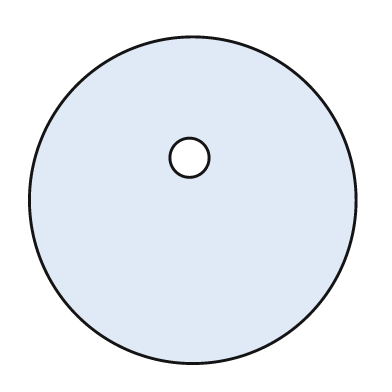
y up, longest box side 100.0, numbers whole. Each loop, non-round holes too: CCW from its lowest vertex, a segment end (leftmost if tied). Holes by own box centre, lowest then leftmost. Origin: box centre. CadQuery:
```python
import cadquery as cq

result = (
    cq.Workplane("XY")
    .moveTo(0.0, 0.0)
    .circle(50.0)
    .moveTo(-1.0, 13.0)
    .circle(6.0)
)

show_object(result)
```